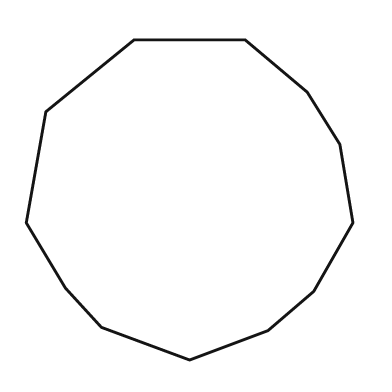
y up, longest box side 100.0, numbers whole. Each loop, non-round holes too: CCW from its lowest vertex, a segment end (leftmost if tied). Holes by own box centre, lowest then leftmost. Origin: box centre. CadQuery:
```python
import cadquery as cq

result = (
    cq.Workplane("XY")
    .moveTo(0.0, -49.0)
    .lineTo(24.0, -40.0)
    .lineTo(38.0, -28.0)
    .lineTo(50.0, -7.0)
    .lineTo(46.0, 17.0)
    .lineTo(36.0, 33.0)
    .lineTo(17.0, 49.0)
    .lineTo(-17.0, 49.0)
    .lineTo(-44.0, 27.0)
    .lineTo(-50.0, -7.0)
    .lineTo(-38.0, -27.0)
    .lineTo(-27.0, -39.0)
    .close()
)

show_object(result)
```